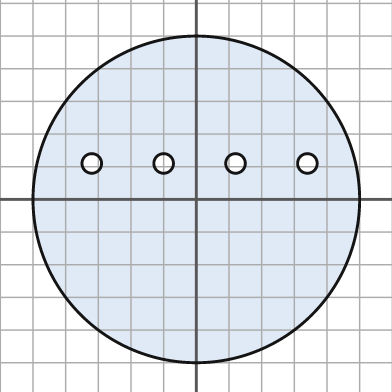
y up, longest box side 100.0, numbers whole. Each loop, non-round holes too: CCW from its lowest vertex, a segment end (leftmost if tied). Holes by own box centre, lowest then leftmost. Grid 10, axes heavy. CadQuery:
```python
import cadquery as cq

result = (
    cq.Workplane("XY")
    .moveTo(0.0, 0.0)
    .circle(50.0)
    .moveTo(-32.0, 11.0)
    .circle(3.0)
    .moveTo(-10.0, 11.0)
    .circle(3.0)
    .moveTo(12.0, 11.0)
    .circle(3.0)
    .moveTo(34.0, 11.0)
    .circle(3.0)
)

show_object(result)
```